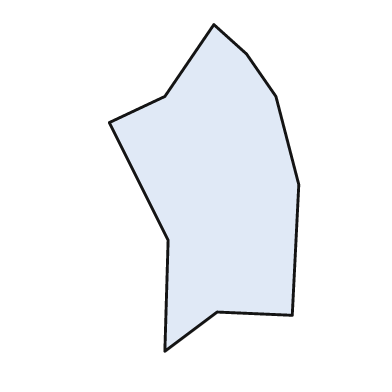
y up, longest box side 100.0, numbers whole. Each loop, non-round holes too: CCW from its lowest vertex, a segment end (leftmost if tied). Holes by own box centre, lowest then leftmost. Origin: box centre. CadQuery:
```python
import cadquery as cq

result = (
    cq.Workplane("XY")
    .moveTo(-12.0, -50.0)
    .lineTo(4.0, -38.0)
    .lineTo(27.0, -39.0)
    .lineTo(29.0, 1.0)
    .lineTo(22.0, 28.0)
    .lineTo(13.0, 41.0)
    .lineTo(3.0, 50.0)
    .lineTo(-12.0, 28.0)
    .lineTo(-29.0, 20.0)
    .lineTo(-11.0, -16.0)
    .close()
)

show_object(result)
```